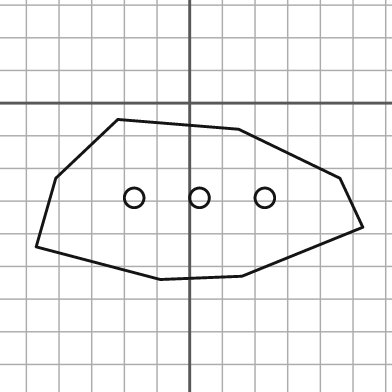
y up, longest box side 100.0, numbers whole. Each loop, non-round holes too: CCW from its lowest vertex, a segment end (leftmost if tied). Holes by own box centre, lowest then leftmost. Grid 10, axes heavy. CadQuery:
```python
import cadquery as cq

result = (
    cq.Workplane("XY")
    .moveTo(-9.0, -54.0)
    .lineTo(16.0, -53.0)
    .lineTo(53.0, -38.0)
    .lineTo(46.0, -23.0)
    .lineTo(15.0, -8.0)
    .lineTo(-22.0, -5.0)
    .lineTo(-41.0, -23.0)
    .lineTo(-47.0, -44.0)
    .close()
    .moveTo(-17.0, -29.0)
    .circle(3.0)
    .moveTo(3.0, -29.0)
    .circle(3.0)
    .moveTo(23.0, -29.0)
    .circle(3.0)
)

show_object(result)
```